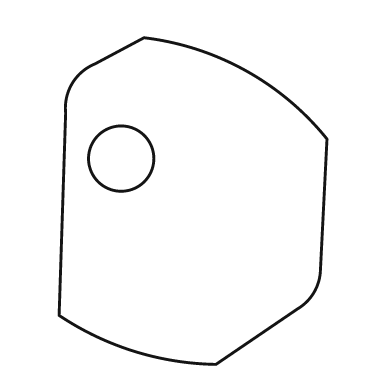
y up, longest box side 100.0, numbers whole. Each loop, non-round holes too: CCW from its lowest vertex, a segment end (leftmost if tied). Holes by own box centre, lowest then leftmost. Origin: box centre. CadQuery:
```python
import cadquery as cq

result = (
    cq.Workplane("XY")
    .moveTo(7.0, -50.0)
    .lineTo(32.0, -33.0)
    .threePointArc((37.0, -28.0), (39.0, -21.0))
    .lineTo(41.0, 19.0)
    .threePointArc((16.0, 40.0), (-15.0, 50.0))
    .lineTo(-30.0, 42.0)
    .threePointArc((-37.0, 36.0), (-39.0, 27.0))
    .lineTo(-41.0, -35.0)
    .threePointArc((-18.0, -46.0), (7.0, -50.0))
    .close()
    .moveTo(-22.0, 13.0)
    .circle(10.0)
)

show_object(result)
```